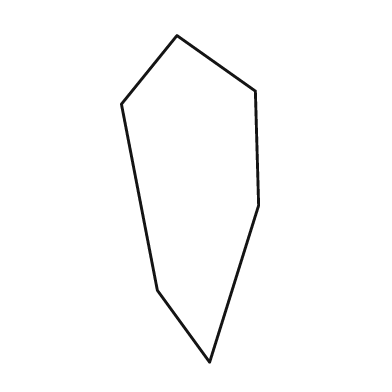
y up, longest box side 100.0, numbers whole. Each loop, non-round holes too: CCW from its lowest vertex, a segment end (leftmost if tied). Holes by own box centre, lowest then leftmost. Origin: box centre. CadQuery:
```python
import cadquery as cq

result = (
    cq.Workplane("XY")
    .moveTo(6.0, -50.0)
    .lineTo(21.0, -2.0)
    .lineTo(20.0, 33.0)
    .lineTo(-4.0, 50.0)
    .lineTo(-21.0, 29.0)
    .lineTo(-10.0, -28.0)
    .close()
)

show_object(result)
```